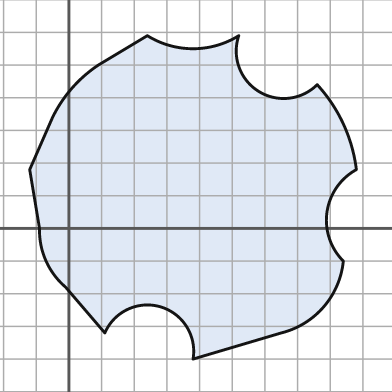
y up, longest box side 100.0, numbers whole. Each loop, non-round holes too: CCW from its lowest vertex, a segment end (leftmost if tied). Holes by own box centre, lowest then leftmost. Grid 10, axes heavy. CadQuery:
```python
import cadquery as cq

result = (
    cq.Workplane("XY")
    .moveTo(38.0, -40.0)
    .lineTo(65.0, -32.0)
    .threePointArc((78.0, -24.0), (84.0, -10.0))
    .threePointArc((79.0, 5.0), (88.0, 18.0))
    .threePointArc((84.0, 32.0), (76.0, 44.0))
    .threePointArc((58.0, 42.0), (52.0, 59.0))
    .threePointArc((38.0, 55.0), (24.0, 59.0))
    .lineTo(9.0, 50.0)
    .threePointArc((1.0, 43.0), (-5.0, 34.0))
    .lineTo(-12.0, 18.0)
    .lineTo(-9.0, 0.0)
    .threePointArc((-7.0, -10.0), (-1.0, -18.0))
    .lineTo(11.0, -32.0)
    .threePointArc((28.0, -24.0), (38.0, -40.0))
    .close()
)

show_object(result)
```